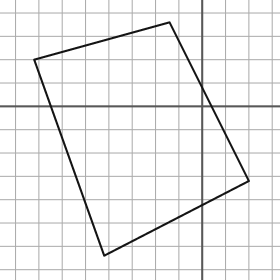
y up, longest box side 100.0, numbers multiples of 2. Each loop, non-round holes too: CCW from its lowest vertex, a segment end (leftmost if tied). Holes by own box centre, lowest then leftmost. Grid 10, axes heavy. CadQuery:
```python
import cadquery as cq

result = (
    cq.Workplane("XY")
    .moveTo(-42.0, -64.0)
    .lineTo(20.0, -32.0)
    .lineTo(-14.0, 36.0)
    .lineTo(-72.0, 20.0)
    .close()
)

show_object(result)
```